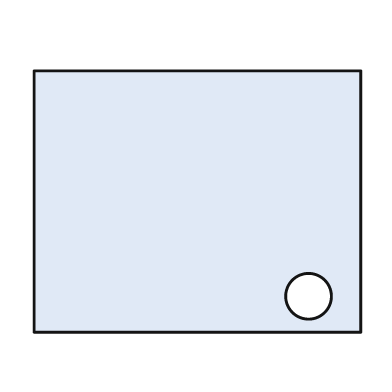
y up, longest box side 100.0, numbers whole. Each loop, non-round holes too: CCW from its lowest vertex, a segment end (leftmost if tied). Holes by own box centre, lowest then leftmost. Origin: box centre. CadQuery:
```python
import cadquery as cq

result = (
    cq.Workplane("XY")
    .moveTo(-50.0, -40.0)
    .lineTo(50.0, -40.0)
    .lineTo(50.0, 40.0)
    .lineTo(-50.0, 40.0)
    .close()
    .moveTo(34.0, -29.0)
    .circle(7.0)
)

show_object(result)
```